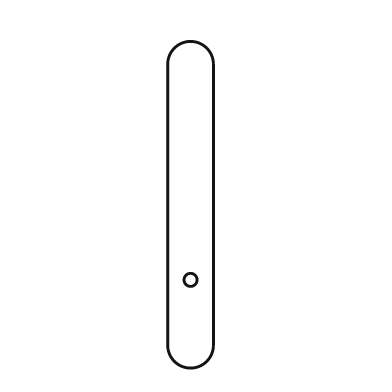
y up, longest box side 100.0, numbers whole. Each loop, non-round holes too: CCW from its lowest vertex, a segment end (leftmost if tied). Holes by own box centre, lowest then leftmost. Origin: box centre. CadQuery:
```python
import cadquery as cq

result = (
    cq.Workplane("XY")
    .moveTo(-7.0, -43.0)
    .threePointArc((0.0, -50.0), (7.0, -43.0))
    .lineTo(7.0, 43.0)
    .threePointArc((0.0, 50.0), (-7.0, 43.0))
    .close()
    .moveTo(0.0, -23.0)
    .circle(2.0)
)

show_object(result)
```